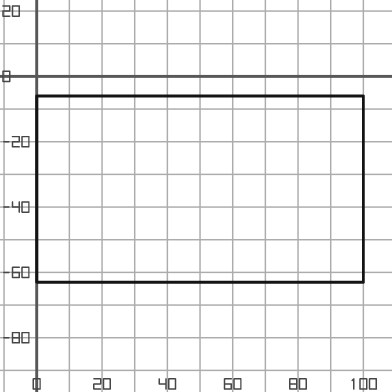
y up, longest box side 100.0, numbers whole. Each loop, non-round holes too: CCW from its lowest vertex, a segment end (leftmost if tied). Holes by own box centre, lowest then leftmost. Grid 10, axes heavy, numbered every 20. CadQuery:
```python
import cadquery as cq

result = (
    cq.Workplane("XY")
    .moveTo(0.0, -63.0)
    .lineTo(100.0, -63.0)
    .lineTo(100.0, -6.0)
    .lineTo(0.0, -6.0)
    .close()
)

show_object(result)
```